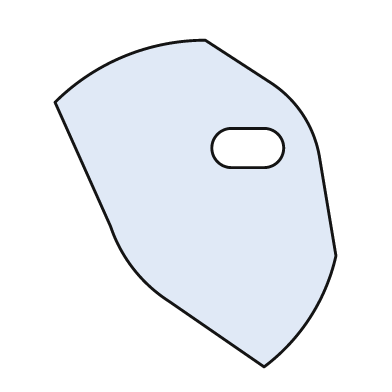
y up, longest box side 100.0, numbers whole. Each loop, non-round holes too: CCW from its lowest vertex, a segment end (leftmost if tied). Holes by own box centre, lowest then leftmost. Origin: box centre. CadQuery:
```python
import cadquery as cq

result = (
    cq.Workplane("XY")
    .moveTo(21.0, -50.0)
    .threePointArc((35.0, -35.0), (43.0, -16.0))
    .lineTo(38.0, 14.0)
    .threePointArc((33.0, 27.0), (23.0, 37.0))
    .lineTo(3.0, 50.0)
    .threePointArc((-22.0, 45.0), (-43.0, 31.0))
    .lineTo(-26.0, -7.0)
    .threePointArc((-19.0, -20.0), (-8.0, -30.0))
    .close()
    .moveTo(11.0, 11.0)
    .lineTo(21.0, 11.0)
    .threePointArc((27.0, 17.0), (21.0, 23.0))
    .lineTo(11.0, 23.0)
    .threePointArc((5.0, 17.0), (11.0, 11.0))
    .close()
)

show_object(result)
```